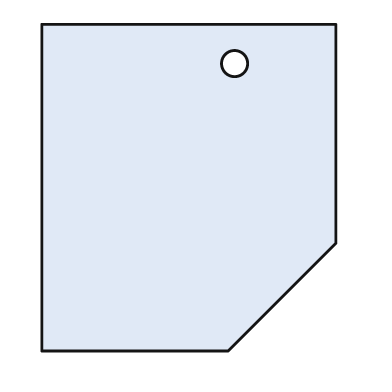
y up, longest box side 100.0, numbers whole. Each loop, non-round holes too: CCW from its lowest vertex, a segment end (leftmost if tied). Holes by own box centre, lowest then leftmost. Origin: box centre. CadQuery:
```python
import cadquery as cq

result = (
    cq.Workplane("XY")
    .moveTo(-45.0, -50.0)
    .lineTo(12.0, -50.0)
    .lineTo(45.0, -17.0)
    .lineTo(45.0, 50.0)
    .lineTo(-45.0, 50.0)
    .close()
    .moveTo(14.0, 38.0)
    .circle(4.0)
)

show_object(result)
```